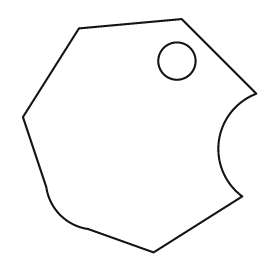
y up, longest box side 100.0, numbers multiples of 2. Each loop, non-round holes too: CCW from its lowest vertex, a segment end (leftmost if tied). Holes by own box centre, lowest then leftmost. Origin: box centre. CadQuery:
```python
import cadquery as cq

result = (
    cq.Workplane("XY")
    .moveTo(6.0, -50.0)
    .lineTo(44.0, -26.0)
    .threePointArc((34.0, -2.0), (50.0, 18.0))
    .lineTo(18.0, 50.0)
    .lineTo(-26.0, 46.0)
    .lineTo(-50.0, 8.0)
    .lineTo(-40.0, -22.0)
    .threePointArc((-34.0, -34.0), (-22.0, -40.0))
    .close()
    .moveTo(16.0, 32.0)
    .circle(8.0)
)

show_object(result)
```